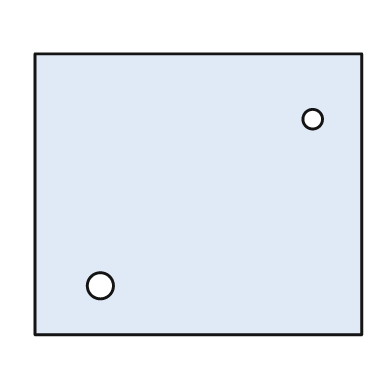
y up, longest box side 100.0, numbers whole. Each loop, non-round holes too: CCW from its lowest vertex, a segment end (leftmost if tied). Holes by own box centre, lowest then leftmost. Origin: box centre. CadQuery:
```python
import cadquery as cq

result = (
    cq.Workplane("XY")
    .moveTo(-50.0, -43.0)
    .lineTo(50.0, -43.0)
    .lineTo(50.0, 43.0)
    .lineTo(-50.0, 43.0)
    .close()
    .moveTo(-30.0, -28.0)
    .circle(4.0)
    .moveTo(35.0, 23.0)
    .circle(3.0)
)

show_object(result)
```